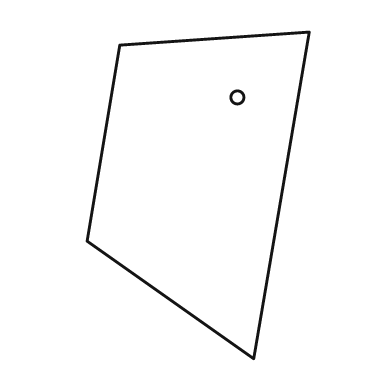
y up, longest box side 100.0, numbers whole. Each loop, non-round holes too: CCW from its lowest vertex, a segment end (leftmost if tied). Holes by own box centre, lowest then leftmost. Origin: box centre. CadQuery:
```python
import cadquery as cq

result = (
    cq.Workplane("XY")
    .moveTo(17.0, -50.0)
    .lineTo(34.0, 50.0)
    .lineTo(-24.0, 46.0)
    .lineTo(-34.0, -14.0)
    .close()
    .moveTo(12.0, 30.0)
    .circle(2.0)
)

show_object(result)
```